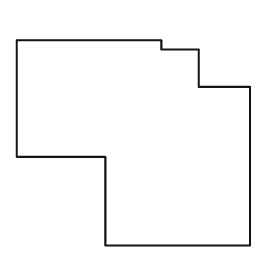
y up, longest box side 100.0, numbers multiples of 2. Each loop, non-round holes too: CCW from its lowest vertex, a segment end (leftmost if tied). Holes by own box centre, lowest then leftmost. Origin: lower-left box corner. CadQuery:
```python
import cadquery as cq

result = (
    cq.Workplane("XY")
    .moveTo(38.0, 0.0)
    .lineTo(100.0, 0.0)
    .lineTo(100.0, 68.0)
    .lineTo(78.0, 68.0)
    .lineTo(78.0, 84.0)
    .lineTo(62.0, 84.0)
    .lineTo(62.0, 88.0)
    .lineTo(0.0, 88.0)
    .lineTo(0.0, 38.0)
    .lineTo(38.0, 38.0)
    .close()
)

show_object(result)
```